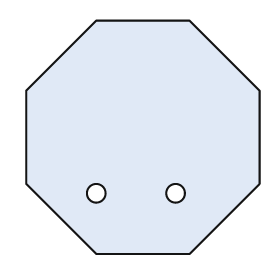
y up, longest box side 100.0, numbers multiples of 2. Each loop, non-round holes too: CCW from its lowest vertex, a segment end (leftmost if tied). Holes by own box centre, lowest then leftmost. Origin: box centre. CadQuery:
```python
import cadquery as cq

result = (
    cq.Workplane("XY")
    .moveTo(-20.0, -50.0)
    .lineTo(20.0, -50.0)
    .lineTo(50.0, -20.0)
    .lineTo(50.0, 20.0)
    .lineTo(20.0, 50.0)
    .lineTo(-20.0, 50.0)
    .lineTo(-50.0, 20.0)
    .lineTo(-50.0, -20.0)
    .close()
    .moveTo(-20.0, -24.0)
    .circle(4.0)
    .moveTo(14.0, -24.0)
    .circle(4.0)
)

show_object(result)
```